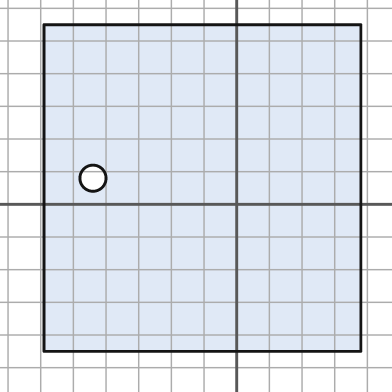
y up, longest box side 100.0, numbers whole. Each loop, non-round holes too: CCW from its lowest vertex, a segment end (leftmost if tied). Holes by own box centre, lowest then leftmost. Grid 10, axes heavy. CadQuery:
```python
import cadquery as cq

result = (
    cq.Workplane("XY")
    .moveTo(-59.0, -45.0)
    .lineTo(38.0, -45.0)
    .lineTo(38.0, 55.0)
    .lineTo(-59.0, 55.0)
    .close()
    .moveTo(-44.0, 8.0)
    .circle(4.0)
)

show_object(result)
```